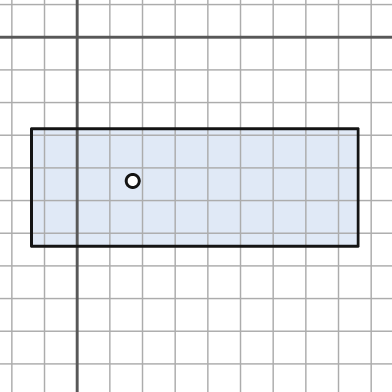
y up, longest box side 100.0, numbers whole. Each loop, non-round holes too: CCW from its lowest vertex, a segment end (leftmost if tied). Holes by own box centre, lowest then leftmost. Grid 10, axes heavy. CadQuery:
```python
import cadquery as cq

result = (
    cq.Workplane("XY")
    .moveTo(-14.0, -64.0)
    .lineTo(86.0, -64.0)
    .lineTo(86.0, -28.0)
    .lineTo(-14.0, -28.0)
    .close()
    .moveTo(17.0, -44.0)
    .circle(2.0)
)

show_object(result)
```